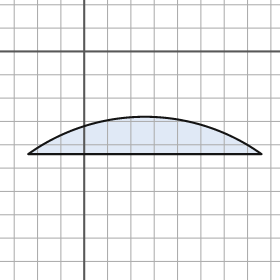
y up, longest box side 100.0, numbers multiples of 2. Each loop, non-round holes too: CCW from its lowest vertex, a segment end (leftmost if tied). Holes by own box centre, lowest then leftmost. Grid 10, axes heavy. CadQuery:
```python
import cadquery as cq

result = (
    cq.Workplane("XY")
    .moveTo(-24.0, -44.0)
    .lineTo(76.0, -44.0)
    .threePointArc((26.0, -28.0), (-24.0, -44.0))
    .close()
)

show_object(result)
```